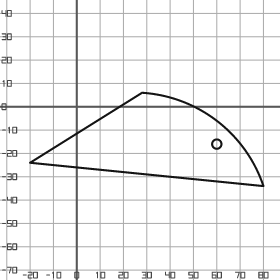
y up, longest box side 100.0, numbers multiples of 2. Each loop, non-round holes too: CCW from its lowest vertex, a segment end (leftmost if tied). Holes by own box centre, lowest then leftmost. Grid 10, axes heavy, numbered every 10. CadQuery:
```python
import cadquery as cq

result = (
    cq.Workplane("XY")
    .moveTo(80.0, -34.0)
    .threePointArc((60.0, -6.0), (28.0, 6.0))
    .lineTo(-20.0, -24.0)
    .close()
    .moveTo(60.0, -16.0)
    .circle(2.0)
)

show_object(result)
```